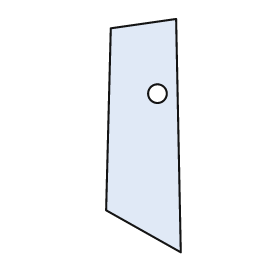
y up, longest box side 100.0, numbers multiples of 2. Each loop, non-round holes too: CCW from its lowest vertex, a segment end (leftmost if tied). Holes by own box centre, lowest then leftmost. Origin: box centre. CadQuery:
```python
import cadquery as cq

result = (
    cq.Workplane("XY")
    .moveTo(16.0, -50.0)
    .lineTo(14.0, 50.0)
    .lineTo(-14.0, 46.0)
    .lineTo(-16.0, -32.0)
    .close()
    .moveTo(6.0, 18.0)
    .circle(4.0)
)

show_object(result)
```